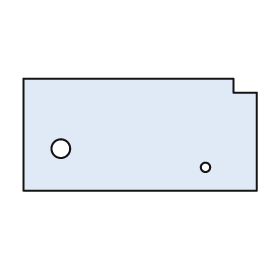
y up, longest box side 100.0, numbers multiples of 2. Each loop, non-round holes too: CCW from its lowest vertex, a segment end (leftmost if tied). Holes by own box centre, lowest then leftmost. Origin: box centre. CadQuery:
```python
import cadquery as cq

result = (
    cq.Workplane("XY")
    .moveTo(-50.0, -24.0)
    .lineTo(50.0, -24.0)
    .lineTo(50.0, 18.0)
    .lineTo(40.0, 18.0)
    .lineTo(40.0, 24.0)
    .lineTo(-50.0, 24.0)
    .close()
    .moveTo(28.0, -14.0)
    .circle(2.0)
    .moveTo(-34.0, -6.0)
    .circle(4.0)
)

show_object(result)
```